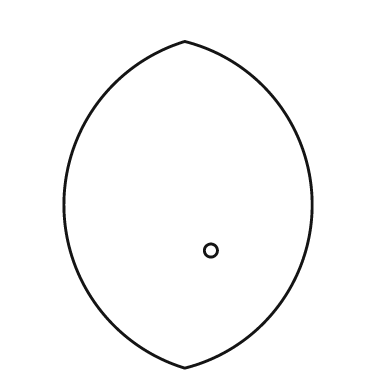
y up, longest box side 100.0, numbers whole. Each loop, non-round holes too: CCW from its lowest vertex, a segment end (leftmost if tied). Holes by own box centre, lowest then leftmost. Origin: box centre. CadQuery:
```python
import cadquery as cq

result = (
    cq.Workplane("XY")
    .moveTo(-1.0, -50.0)
    .threePointArc((38.0, 0.0), (-1.0, 50.0))
    .threePointArc((-38.0, 0.0), (-1.0, -50.0))
    .close()
    .moveTo(7.0, -14.0)
    .circle(2.0)
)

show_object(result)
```